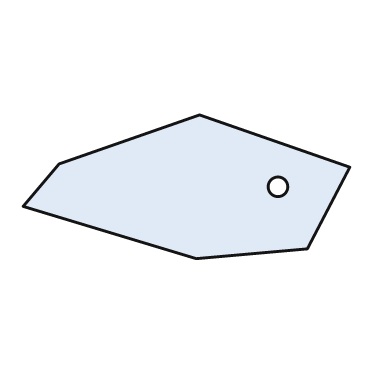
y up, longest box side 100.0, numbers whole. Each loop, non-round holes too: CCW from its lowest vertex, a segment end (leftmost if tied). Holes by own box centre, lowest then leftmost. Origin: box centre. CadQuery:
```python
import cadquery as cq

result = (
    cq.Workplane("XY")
    .moveTo(3.0, -22.0)
    .lineTo(37.0, -19.0)
    .lineTo(50.0, 6.0)
    .lineTo(4.0, 22.0)
    .lineTo(-39.0, 7.0)
    .lineTo(-50.0, -6.0)
    .close()
    .moveTo(28.0, 0.0)
    .circle(3.0)
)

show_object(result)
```